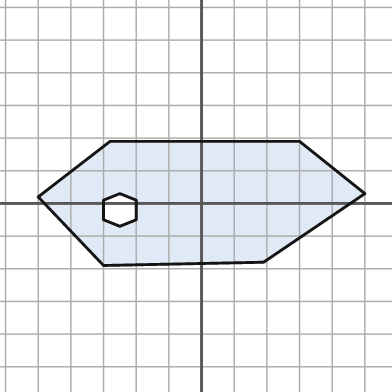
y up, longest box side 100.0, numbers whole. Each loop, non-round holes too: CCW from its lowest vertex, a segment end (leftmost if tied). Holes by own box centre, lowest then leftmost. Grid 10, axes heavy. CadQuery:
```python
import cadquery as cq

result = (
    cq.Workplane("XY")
    .moveTo(-30.0, -19.0)
    .lineTo(19.0, -18.0)
    .lineTo(50.0, 3.0)
    .lineTo(30.0, 19.0)
    .lineTo(-28.0, 19.0)
    .lineTo(-50.0, 2.0)
    .close()
    .moveTo(-25.0, -7.0)
    .lineTo(-20.0, -5.0)
    .lineTo(-20.0, 1.0)
    .lineTo(-25.0, 3.0)
    .lineTo(-30.0, 1.0)
    .lineTo(-30.0, -5.0)
    .close()
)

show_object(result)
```